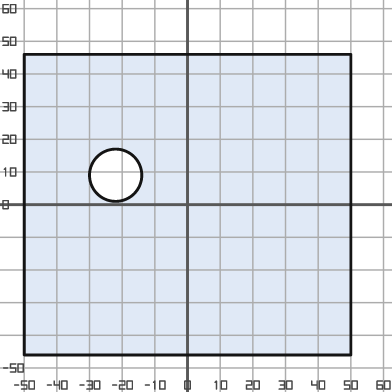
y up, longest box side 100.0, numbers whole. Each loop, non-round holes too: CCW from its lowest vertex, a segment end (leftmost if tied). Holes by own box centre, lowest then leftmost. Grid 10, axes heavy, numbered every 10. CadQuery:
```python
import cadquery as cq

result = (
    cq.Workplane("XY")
    .moveTo(-50.0, -46.0)
    .lineTo(50.0, -46.0)
    .lineTo(50.0, 46.0)
    .lineTo(-50.0, 46.0)
    .close()
    .moveTo(-22.0, 9.0)
    .circle(8.0)
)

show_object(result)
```